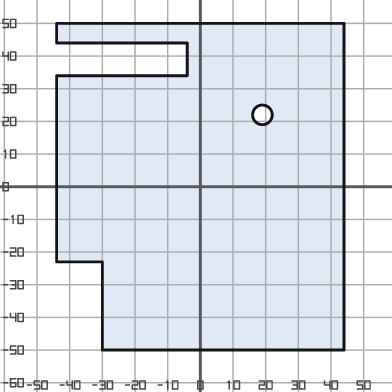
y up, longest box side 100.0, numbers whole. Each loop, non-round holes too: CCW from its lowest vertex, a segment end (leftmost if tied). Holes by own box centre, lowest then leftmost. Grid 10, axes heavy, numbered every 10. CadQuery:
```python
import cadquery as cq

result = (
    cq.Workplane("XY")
    .moveTo(-30.0, -50.0)
    .lineTo(44.0, -50.0)
    .lineTo(44.0, 50.0)
    .lineTo(-44.0, 50.0)
    .lineTo(-44.0, 44.0)
    .lineTo(-4.0, 44.0)
    .lineTo(-4.0, 34.0)
    .lineTo(-44.0, 34.0)
    .lineTo(-44.0, -23.0)
    .lineTo(-30.0, -23.0)
    .close()
    .moveTo(19.0, 22.0)
    .circle(3.0)
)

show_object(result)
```